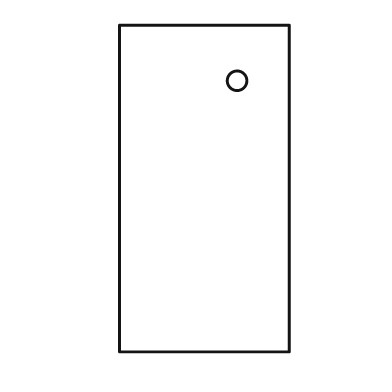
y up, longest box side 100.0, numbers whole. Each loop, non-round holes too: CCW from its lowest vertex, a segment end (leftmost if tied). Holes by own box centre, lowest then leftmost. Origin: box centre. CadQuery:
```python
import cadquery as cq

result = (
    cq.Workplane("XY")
    .moveTo(-26.0, -50.0)
    .lineTo(26.0, -50.0)
    .lineTo(26.0, 50.0)
    .lineTo(-26.0, 50.0)
    .close()
    .moveTo(10.0, 33.0)
    .circle(3.0)
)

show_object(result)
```